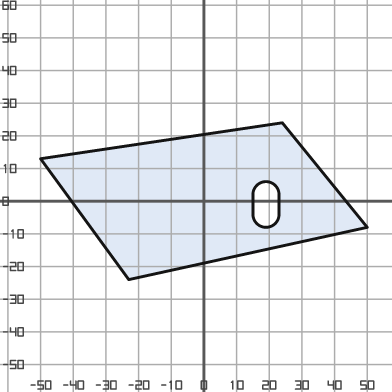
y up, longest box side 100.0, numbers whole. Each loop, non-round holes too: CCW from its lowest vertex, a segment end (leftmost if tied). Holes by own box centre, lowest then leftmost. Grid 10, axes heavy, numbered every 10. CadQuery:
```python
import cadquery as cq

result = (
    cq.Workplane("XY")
    .moveTo(-23.0, -24.0)
    .lineTo(50.0, -8.0)
    .lineTo(24.0, 24.0)
    .lineTo(-50.0, 13.0)
    .close()
    .moveTo(15.0, -4.0)
    .threePointArc((19.0, -8.0), (23.0, -4.0))
    .lineTo(23.0, 2.0)
    .threePointArc((19.0, 6.0), (15.0, 2.0))
    .close()
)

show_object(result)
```